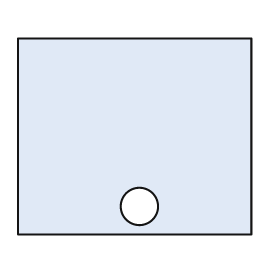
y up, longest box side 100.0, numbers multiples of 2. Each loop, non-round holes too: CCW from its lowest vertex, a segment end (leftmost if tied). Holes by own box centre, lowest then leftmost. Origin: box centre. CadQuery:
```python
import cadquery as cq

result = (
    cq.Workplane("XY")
    .moveTo(-50.0, -42.0)
    .lineTo(50.0, -42.0)
    .lineTo(50.0, 42.0)
    .lineTo(-50.0, 42.0)
    .close()
    .moveTo(2.0, -30.0)
    .circle(8.0)
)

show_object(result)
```